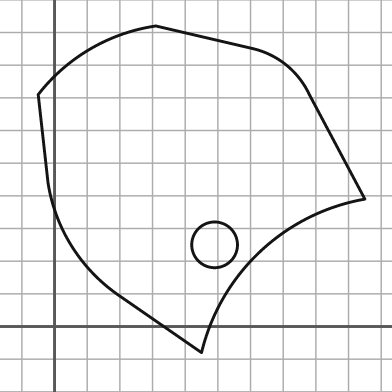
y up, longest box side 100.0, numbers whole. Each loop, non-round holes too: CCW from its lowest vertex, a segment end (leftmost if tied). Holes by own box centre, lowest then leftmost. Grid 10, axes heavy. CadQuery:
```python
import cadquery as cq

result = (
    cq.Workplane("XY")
    .moveTo(45.0, -8.0)
    .threePointArc((63.0, 23.0), (95.0, 39.0))
    .lineTo(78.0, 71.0)
    .threePointArc((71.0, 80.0), (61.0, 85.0))
    .lineTo(31.0, 92.0)
    .threePointArc((11.0, 85.0), (-5.0, 71.0))
    .lineTo(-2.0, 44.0)
    .threePointArc((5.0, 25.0), (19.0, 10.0))
    .close()
    .moveTo(49.0, 25.0)
    .circle(7.0)
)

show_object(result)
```